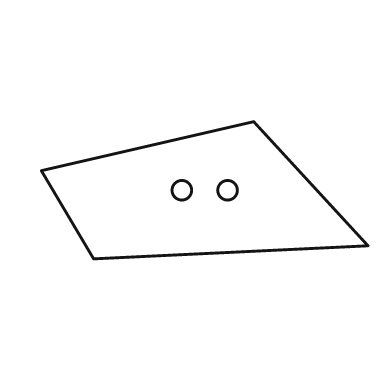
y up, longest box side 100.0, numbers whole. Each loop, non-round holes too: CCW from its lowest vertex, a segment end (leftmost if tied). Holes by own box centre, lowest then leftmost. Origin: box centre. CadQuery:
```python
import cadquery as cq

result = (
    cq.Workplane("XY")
    .moveTo(-34.0, -21.0)
    .lineTo(50.0, -17.0)
    .lineTo(15.0, 21.0)
    .lineTo(-50.0, 6.0)
    .close()
    .moveTo(-7.0, 0.0)
    .circle(3.0)
    .moveTo(7.0, 0.0)
    .circle(3.0)
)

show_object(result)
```